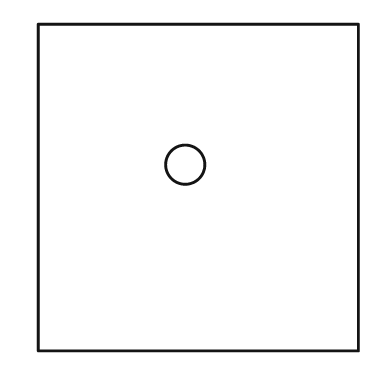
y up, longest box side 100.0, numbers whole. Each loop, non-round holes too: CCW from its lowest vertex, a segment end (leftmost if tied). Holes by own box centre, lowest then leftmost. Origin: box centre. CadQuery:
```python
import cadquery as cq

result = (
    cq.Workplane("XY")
    .moveTo(-49.0, -50.0)
    .lineTo(49.0, -50.0)
    .lineTo(49.0, 50.0)
    .lineTo(-49.0, 50.0)
    .close()
    .moveTo(-4.0, 7.0)
    .circle(6.0)
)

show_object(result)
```